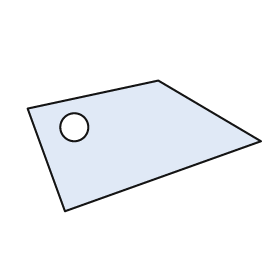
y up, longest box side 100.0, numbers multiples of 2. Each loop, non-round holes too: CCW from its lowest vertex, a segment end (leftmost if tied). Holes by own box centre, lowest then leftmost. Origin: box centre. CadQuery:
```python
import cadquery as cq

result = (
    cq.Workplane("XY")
    .moveTo(-34.0, -28.0)
    .lineTo(50.0, 2.0)
    .lineTo(6.0, 28.0)
    .lineTo(-50.0, 16.0)
    .close()
    .moveTo(-30.0, 8.0)
    .circle(6.0)
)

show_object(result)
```